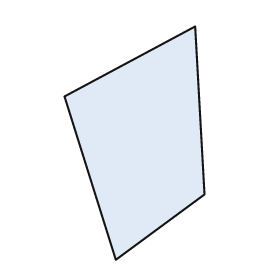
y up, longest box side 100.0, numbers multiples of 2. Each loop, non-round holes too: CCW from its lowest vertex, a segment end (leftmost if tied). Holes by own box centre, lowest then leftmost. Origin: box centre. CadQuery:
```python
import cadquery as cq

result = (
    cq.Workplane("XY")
    .moveTo(-8.0, -50.0)
    .lineTo(30.0, -22.0)
    .lineTo(26.0, 50.0)
    .lineTo(-30.0, 20.0)
    .close()
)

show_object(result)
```